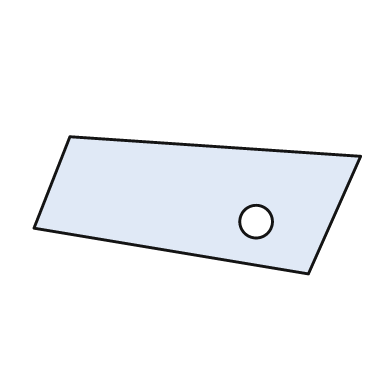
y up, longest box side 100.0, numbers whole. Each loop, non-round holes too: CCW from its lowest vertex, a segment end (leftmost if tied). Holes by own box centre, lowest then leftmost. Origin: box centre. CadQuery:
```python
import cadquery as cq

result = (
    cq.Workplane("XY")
    .moveTo(34.0, -21.0)
    .lineTo(50.0, 15.0)
    .lineTo(-39.0, 21.0)
    .lineTo(-50.0, -7.0)
    .close()
    .moveTo(18.0, -5.0)
    .circle(5.0)
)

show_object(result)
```